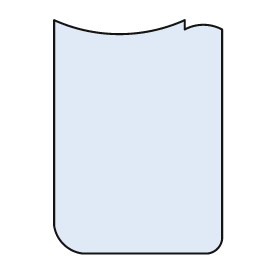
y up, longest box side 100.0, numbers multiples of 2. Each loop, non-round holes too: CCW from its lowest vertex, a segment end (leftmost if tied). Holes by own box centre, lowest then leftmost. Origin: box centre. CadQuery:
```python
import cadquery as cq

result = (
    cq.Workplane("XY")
    .moveTo(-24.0, -50.0)
    .lineTo(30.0, -50.0)
    .threePointArc((34.0, -48.0), (36.0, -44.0))
    .lineTo(36.0, 46.0)
    .threePointArc((28.0, 48.0), (20.0, 46.0))
    .lineTo(20.0, 50.0)
    .threePointArc((-8.0, 44.0), (-36.0, 50.0))
    .lineTo(-36.0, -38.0)
    .threePointArc((-32.0, -46.0), (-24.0, -50.0))
    .close()
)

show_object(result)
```